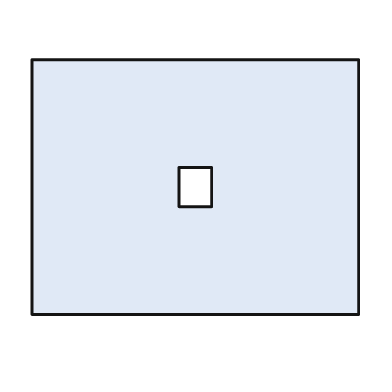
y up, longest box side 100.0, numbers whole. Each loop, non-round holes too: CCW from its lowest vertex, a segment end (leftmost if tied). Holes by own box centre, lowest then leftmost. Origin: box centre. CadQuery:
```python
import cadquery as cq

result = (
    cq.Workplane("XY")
    .moveTo(-50.0, -39.0)
    .lineTo(50.0, -39.0)
    .lineTo(50.0, 39.0)
    .lineTo(-50.0, 39.0)
    .close()
    .moveTo(-5.0, -6.0)
    .lineTo(5.0, -6.0)
    .lineTo(5.0, 6.0)
    .lineTo(-5.0, 6.0)
    .close()
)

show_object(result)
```